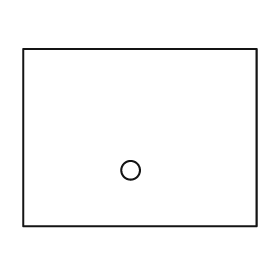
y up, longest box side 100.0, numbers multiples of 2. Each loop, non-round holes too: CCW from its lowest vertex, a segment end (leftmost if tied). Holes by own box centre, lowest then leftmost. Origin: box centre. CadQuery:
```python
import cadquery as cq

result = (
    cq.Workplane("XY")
    .moveTo(-50.0, -38.0)
    .lineTo(50.0, -38.0)
    .lineTo(50.0, 38.0)
    .lineTo(-50.0, 38.0)
    .close()
    .moveTo(-4.0, -14.0)
    .circle(4.0)
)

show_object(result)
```